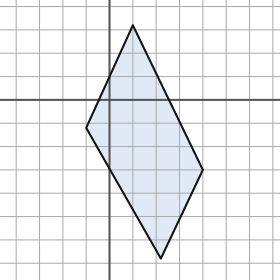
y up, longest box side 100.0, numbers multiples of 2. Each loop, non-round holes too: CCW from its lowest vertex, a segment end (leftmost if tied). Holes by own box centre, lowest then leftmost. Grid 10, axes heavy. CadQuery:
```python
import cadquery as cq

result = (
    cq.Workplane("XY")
    .moveTo(22.0, -68.0)
    .lineTo(40.0, -30.0)
    .lineTo(10.0, 32.0)
    .lineTo(-10.0, -12.0)
    .close()
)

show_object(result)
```